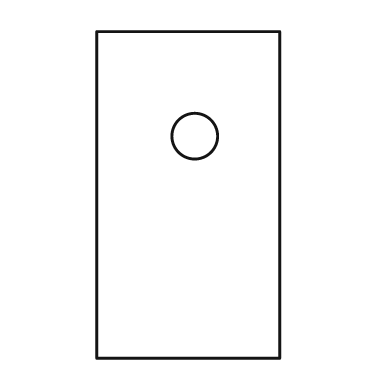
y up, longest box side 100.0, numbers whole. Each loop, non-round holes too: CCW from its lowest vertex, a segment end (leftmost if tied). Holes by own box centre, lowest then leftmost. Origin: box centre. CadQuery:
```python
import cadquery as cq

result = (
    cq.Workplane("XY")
    .moveTo(-28.0, -50.0)
    .lineTo(28.0, -50.0)
    .lineTo(28.0, 50.0)
    .lineTo(-28.0, 50.0)
    .close()
    .moveTo(2.0, 18.0)
    .circle(7.0)
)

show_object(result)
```